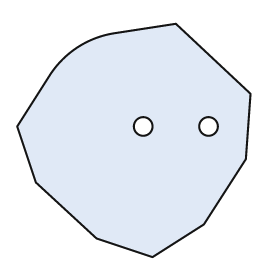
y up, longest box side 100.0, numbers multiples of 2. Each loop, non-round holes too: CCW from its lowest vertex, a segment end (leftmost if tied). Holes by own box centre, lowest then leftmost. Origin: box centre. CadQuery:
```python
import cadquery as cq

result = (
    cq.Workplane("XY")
    .moveTo(8.0, -50.0)
    .lineTo(30.0, -36.0)
    .lineTo(48.0, -8.0)
    .lineTo(50.0, 20.0)
    .lineTo(18.0, 50.0)
    .lineTo(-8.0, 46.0)
    .threePointArc((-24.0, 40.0), (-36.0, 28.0))
    .lineTo(-50.0, 6.0)
    .lineTo(-42.0, -18.0)
    .lineTo(-16.0, -42.0)
    .close()
    .moveTo(4.0, 6.0)
    .circle(4.0)
    .moveTo(32.0, 6.0)
    .circle(4.0)
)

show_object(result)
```